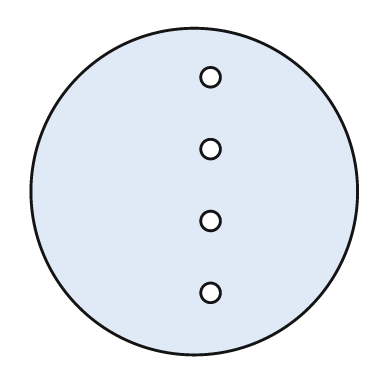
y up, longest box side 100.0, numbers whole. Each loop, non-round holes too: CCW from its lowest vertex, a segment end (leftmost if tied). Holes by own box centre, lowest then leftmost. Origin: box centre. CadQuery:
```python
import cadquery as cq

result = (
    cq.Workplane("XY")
    .moveTo(0.0, 0.0)
    .circle(50.0)
    .moveTo(5.0, -31.0)
    .circle(3.0)
    .moveTo(5.0, -9.0)
    .circle(3.0)
    .moveTo(5.0, 13.0)
    .circle(3.0)
    .moveTo(5.0, 35.0)
    .circle(3.0)
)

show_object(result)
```